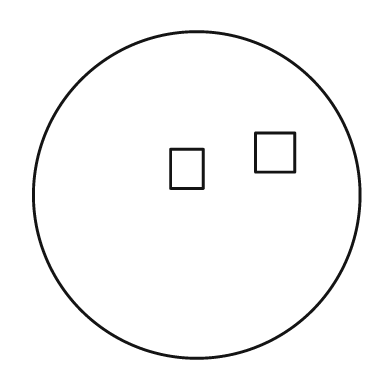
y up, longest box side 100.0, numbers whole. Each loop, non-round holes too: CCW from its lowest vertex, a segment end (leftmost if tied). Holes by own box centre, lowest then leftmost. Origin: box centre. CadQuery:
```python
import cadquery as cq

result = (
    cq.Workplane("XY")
    .moveTo(0.0, 0.0)
    .circle(50.0)
    .moveTo(-8.0, 2.0)
    .lineTo(2.0, 2.0)
    .lineTo(2.0, 14.0)
    .lineTo(-8.0, 14.0)
    .close()
    .moveTo(18.0, 7.0)
    .lineTo(30.0, 7.0)
    .lineTo(30.0, 19.0)
    .lineTo(18.0, 19.0)
    .close()
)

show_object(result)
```